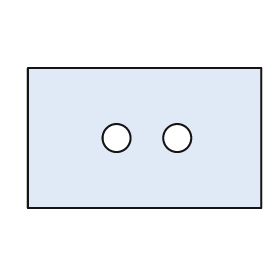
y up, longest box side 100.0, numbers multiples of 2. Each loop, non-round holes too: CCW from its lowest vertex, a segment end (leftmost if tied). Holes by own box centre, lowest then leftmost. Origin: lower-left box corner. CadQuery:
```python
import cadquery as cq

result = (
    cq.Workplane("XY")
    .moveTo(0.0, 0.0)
    .lineTo(100.0, 0.0)
    .lineTo(100.0, 60.0)
    .lineTo(0.0, 60.0)
    .close()
    .moveTo(38.0, 30.0)
    .circle(6.0)
    .moveTo(64.0, 30.0)
    .circle(6.0)
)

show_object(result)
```